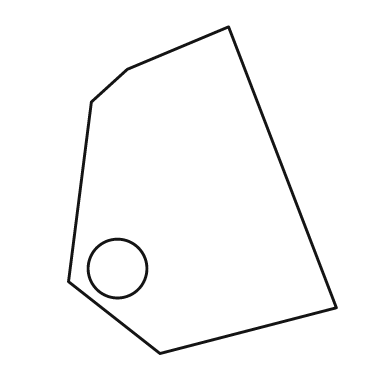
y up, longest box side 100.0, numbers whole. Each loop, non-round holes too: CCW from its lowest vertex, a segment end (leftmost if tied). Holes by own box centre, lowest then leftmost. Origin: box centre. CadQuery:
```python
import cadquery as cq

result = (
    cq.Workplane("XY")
    .moveTo(-13.0, -50.0)
    .lineTo(41.0, -36.0)
    .lineTo(8.0, 50.0)
    .lineTo(-23.0, 37.0)
    .lineTo(-34.0, 27.0)
    .lineTo(-41.0, -28.0)
    .close()
    .moveTo(-26.0, -24.0)
    .circle(9.0)
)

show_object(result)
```